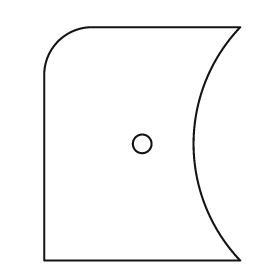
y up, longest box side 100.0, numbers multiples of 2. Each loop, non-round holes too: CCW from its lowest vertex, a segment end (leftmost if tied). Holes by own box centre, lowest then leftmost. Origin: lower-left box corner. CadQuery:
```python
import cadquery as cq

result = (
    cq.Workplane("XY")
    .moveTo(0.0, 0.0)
    .lineTo(84.0, 0.0)
    .threePointArc((64.0, 50.0), (84.0, 100.0))
    .lineTo(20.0, 100.0)
    .threePointArc((6.0, 94.0), (0.0, 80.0))
    .close()
    .moveTo(42.0, 50.0)
    .circle(4.0)
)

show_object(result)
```